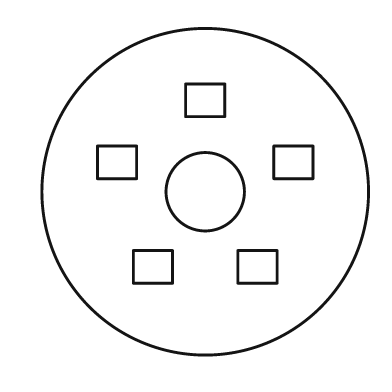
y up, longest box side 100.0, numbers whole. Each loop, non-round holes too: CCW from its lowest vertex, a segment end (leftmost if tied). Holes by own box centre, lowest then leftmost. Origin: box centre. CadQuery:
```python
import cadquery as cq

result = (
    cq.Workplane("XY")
    .moveTo(0.0, 0.0)
    .circle(50.0)
    .moveTo(-22.0, -28.0)
    .lineTo(-10.0, -28.0)
    .lineTo(-10.0, -18.0)
    .lineTo(-22.0, -18.0)
    .close()
    .moveTo(10.0, -28.0)
    .lineTo(22.0, -28.0)
    .lineTo(22.0, -18.0)
    .lineTo(10.0, -18.0)
    .close()
    .moveTo(0.0, 0.0)
    .circle(12.0)
    .moveTo(-33.0, 4.0)
    .lineTo(-21.0, 4.0)
    .lineTo(-21.0, 14.0)
    .lineTo(-33.0, 14.0)
    .close()
    .moveTo(21.0, 4.0)
    .lineTo(33.0, 4.0)
    .lineTo(33.0, 14.0)
    .lineTo(21.0, 14.0)
    .close()
    .moveTo(-6.0, 23.0)
    .lineTo(6.0, 23.0)
    .lineTo(6.0, 33.0)
    .lineTo(-6.0, 33.0)
    .close()
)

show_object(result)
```